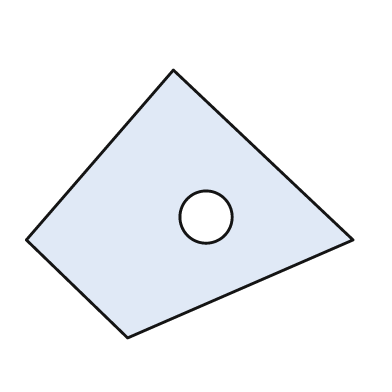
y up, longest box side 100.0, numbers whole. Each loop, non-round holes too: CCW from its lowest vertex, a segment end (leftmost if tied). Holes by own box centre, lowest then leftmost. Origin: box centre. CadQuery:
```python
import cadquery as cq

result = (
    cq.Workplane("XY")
    .moveTo(-19.0, -41.0)
    .lineTo(50.0, -11.0)
    .lineTo(-5.0, 41.0)
    .lineTo(-50.0, -11.0)
    .close()
    .moveTo(5.0, -4.0)
    .circle(8.0)
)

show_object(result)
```